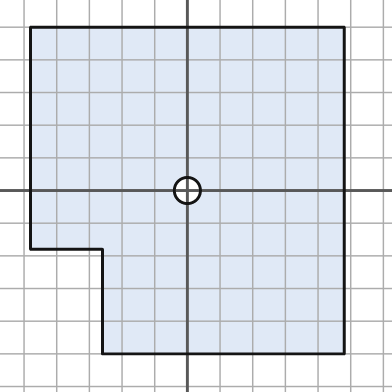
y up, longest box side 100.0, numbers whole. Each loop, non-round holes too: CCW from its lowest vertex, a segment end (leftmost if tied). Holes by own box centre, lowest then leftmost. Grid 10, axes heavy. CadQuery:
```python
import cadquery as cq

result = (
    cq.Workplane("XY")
    .moveTo(-26.0, -50.0)
    .lineTo(48.0, -50.0)
    .lineTo(48.0, 50.0)
    .lineTo(-48.0, 50.0)
    .lineTo(-48.0, -18.0)
    .lineTo(-26.0, -18.0)
    .close()
    .moveTo(0.0, 0.0)
    .circle(4.0)
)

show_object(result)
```